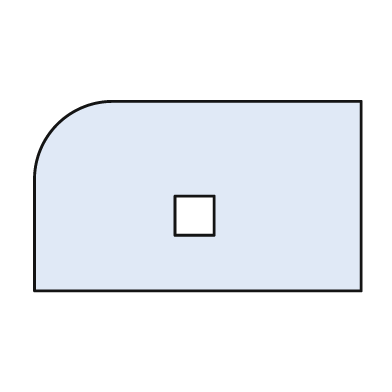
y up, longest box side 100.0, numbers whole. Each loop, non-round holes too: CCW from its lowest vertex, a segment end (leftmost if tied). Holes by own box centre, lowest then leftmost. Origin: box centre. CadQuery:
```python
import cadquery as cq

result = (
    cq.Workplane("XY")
    .moveTo(-50.0, -29.0)
    .lineTo(50.0, -29.0)
    .lineTo(50.0, 29.0)
    .lineTo(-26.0, 29.0)
    .threePointArc((-43.0, 22.0), (-50.0, 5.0))
    .close()
    .moveTo(-7.0, -12.0)
    .lineTo(5.0, -12.0)
    .lineTo(5.0, 0.0)
    .lineTo(-7.0, 0.0)
    .close()
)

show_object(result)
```